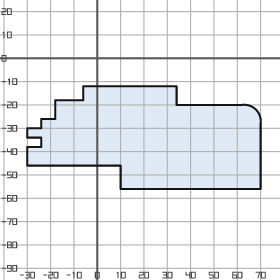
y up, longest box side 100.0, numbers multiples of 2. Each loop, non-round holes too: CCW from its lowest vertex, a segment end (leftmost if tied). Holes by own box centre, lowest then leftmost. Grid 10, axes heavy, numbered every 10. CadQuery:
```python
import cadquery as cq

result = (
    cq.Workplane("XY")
    .moveTo(10.0, -56.0)
    .lineTo(70.0, -56.0)
    .lineTo(70.0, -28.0)
    .threePointArc((68.0, -22.0), (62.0, -20.0))
    .lineTo(34.0, -20.0)
    .lineTo(34.0, -12.0)
    .lineTo(-6.0, -12.0)
    .lineTo(-6.0, -18.0)
    .lineTo(-18.0, -18.0)
    .lineTo(-18.0, -26.0)
    .lineTo(-24.0, -26.0)
    .lineTo(-24.0, -30.0)
    .lineTo(-30.0, -30.0)
    .lineTo(-30.0, -34.0)
    .lineTo(-24.0, -34.0)
    .lineTo(-24.0, -38.0)
    .lineTo(-30.0, -38.0)
    .lineTo(-30.0, -46.0)
    .lineTo(10.0, -46.0)
    .close()
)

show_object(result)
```